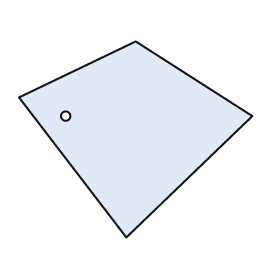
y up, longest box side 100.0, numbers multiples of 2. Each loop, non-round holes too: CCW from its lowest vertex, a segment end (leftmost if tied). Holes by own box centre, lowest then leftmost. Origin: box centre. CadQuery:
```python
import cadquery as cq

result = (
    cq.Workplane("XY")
    .moveTo(-4.0, -42.0)
    .lineTo(50.0, 10.0)
    .lineTo(0.0, 42.0)
    .lineTo(-50.0, 18.0)
    .close()
    .moveTo(-30.0, 10.0)
    .circle(2.0)
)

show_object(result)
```